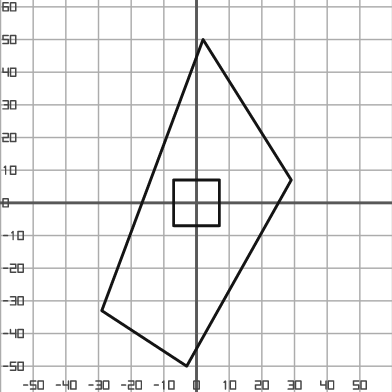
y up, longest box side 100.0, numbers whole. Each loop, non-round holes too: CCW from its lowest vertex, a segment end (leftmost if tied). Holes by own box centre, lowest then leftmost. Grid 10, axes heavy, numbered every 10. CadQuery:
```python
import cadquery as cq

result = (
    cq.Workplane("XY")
    .moveTo(-3.0, -50.0)
    .lineTo(29.0, 7.0)
    .lineTo(2.0, 50.0)
    .lineTo(-29.0, -33.0)
    .close()
    .moveTo(-7.0, -7.0)
    .lineTo(7.0, -7.0)
    .lineTo(7.0, 7.0)
    .lineTo(-7.0, 7.0)
    .close()
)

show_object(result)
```